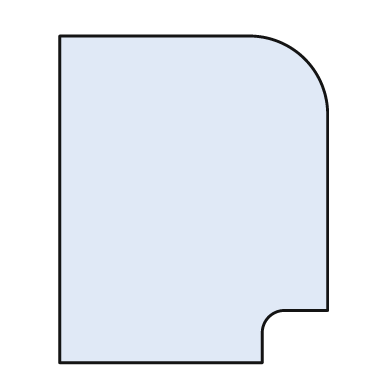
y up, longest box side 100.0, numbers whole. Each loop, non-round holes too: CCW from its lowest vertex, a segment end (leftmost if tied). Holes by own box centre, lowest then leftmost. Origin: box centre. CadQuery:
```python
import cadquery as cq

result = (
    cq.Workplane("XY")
    .moveTo(-41.0, -50.0)
    .lineTo(21.0, -50.0)
    .lineTo(21.0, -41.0)
    .threePointArc((23.0, -36.0), (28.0, -34.0))
    .lineTo(41.0, -34.0)
    .lineTo(41.0, 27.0)
    .threePointArc((34.0, 43.0), (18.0, 50.0))
    .lineTo(-41.0, 50.0)
    .close()
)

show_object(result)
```